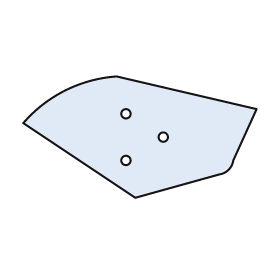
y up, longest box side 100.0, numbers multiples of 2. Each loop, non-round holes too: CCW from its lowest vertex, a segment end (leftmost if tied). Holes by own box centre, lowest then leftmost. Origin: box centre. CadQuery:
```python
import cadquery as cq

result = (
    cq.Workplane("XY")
    .moveTo(-2.0, -26.0)
    .lineTo(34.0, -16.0)
    .threePointArc((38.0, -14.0), (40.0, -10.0))
    .lineTo(50.0, 12.0)
    .lineTo(-10.0, 26.0)
    .threePointArc((-32.0, 20.0), (-50.0, 6.0))
    .close()
    .moveTo(-6.0, -10.0)
    .circle(2.0)
    .moveTo(10.0, 0.0)
    .circle(2.0)
    .moveTo(-6.0, 10.0)
    .circle(2.0)
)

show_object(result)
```